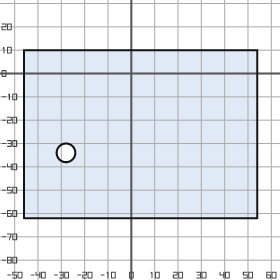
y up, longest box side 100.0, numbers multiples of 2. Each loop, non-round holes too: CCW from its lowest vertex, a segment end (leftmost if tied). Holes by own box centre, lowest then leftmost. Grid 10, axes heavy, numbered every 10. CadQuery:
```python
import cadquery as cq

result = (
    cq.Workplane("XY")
    .moveTo(-46.0, -62.0)
    .lineTo(54.0, -62.0)
    .lineTo(54.0, 10.0)
    .lineTo(-46.0, 10.0)
    .close()
    .moveTo(-28.0, -34.0)
    .circle(4.0)
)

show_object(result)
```